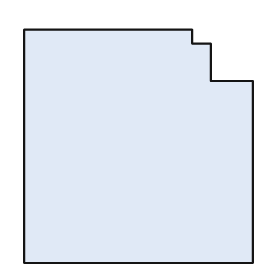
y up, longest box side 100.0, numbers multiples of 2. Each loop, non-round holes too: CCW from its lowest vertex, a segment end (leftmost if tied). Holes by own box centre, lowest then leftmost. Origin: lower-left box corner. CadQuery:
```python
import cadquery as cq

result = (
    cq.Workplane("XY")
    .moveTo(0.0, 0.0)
    .lineTo(98.0, 0.0)
    .lineTo(98.0, 78.0)
    .lineTo(80.0, 78.0)
    .lineTo(80.0, 94.0)
    .lineTo(72.0, 94.0)
    .lineTo(72.0, 100.0)
    .lineTo(0.0, 100.0)
    .close()
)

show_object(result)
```